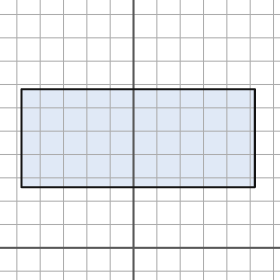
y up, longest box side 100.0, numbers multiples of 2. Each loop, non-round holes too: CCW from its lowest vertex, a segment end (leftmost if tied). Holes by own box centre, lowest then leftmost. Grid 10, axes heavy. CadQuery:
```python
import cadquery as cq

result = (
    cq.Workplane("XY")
    .moveTo(-48.0, 26.0)
    .lineTo(52.0, 26.0)
    .lineTo(52.0, 68.0)
    .lineTo(-48.0, 68.0)
    .close()
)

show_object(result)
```